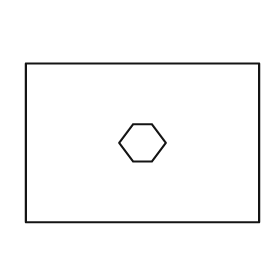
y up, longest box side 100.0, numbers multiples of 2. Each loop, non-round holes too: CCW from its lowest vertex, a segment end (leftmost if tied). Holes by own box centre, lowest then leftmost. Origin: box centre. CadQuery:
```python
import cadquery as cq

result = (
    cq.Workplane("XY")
    .moveTo(-50.0, -34.0)
    .lineTo(50.0, -34.0)
    .lineTo(50.0, 34.0)
    .lineTo(-50.0, 34.0)
    .close()
    .moveTo(-4.0, -8.0)
    .lineTo(4.0, -8.0)
    .lineTo(10.0, 0.0)
    .lineTo(4.0, 8.0)
    .lineTo(-4.0, 8.0)
    .lineTo(-10.0, 0.0)
    .close()
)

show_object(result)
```